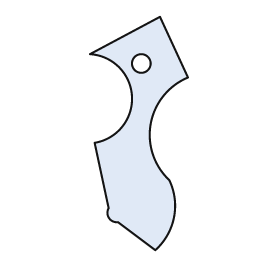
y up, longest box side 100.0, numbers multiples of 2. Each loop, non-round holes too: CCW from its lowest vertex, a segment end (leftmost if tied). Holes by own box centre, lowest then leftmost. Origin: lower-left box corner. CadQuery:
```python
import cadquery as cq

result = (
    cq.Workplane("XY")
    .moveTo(28.0, 0.0)
    .threePointArc((36.0, 14.0), (34.0, 30.0))
    .threePointArc((26.0, 54.0), (42.0, 74.0))
    .lineTo(30.0, 100.0)
    .lineTo(0.0, 84.0)
    .threePointArc((18.0, 66.0), (2.0, 46.0))
    .lineTo(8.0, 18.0)
    .threePointArc((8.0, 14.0), (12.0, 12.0))
    .close()
    .moveTo(22.0, 80.0)
    .circle(4.0)
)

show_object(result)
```